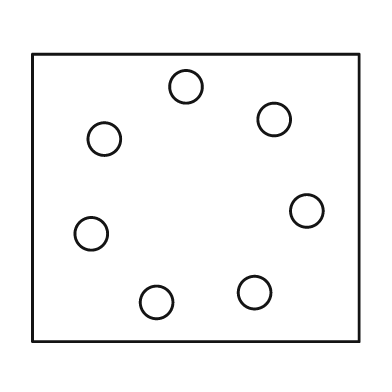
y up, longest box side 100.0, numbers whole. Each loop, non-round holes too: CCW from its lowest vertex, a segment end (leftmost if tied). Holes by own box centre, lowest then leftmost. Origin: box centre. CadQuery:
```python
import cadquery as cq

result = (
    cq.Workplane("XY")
    .moveTo(-50.0, -44.0)
    .lineTo(50.0, -44.0)
    .lineTo(50.0, 44.0)
    .lineTo(-50.0, 44.0)
    .close()
    .moveTo(-12.0, -32.0)
    .circle(5.0)
    .moveTo(18.0, -29.0)
    .circle(5.0)
    .moveTo(-32.0, -11.0)
    .circle(5.0)
    .moveTo(34.0, -4.0)
    .circle(5.0)
    .moveTo(-28.0, 18.0)
    .circle(5.0)
    .moveTo(24.0, 24.0)
    .circle(5.0)
    .moveTo(-3.0, 34.0)
    .circle(5.0)
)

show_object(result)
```